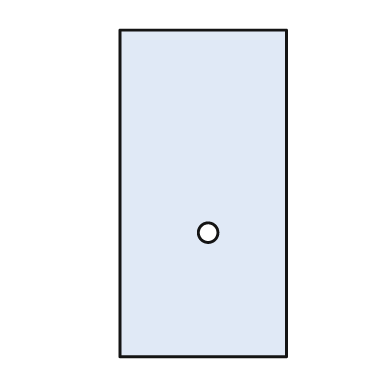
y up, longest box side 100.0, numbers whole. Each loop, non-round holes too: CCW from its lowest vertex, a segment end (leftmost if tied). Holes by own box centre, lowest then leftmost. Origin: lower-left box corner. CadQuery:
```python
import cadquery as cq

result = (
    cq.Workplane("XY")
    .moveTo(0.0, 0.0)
    .lineTo(51.0, 0.0)
    .lineTo(51.0, 100.0)
    .lineTo(0.0, 100.0)
    .close()
    .moveTo(27.0, 38.0)
    .circle(3.0)
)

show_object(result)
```